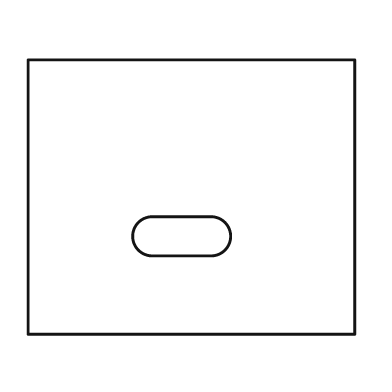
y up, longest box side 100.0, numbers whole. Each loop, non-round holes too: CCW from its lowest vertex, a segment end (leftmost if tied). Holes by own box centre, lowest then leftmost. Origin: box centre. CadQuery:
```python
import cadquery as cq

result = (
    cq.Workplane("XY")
    .moveTo(-50.0, -42.0)
    .lineTo(50.0, -42.0)
    .lineTo(50.0, 42.0)
    .lineTo(-50.0, 42.0)
    .close()
    .moveTo(-12.0, -18.0)
    .lineTo(6.0, -18.0)
    .threePointArc((12.0, -12.0), (6.0, -6.0))
    .lineTo(-12.0, -6.0)
    .threePointArc((-18.0, -12.0), (-12.0, -18.0))
    .close()
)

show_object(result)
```